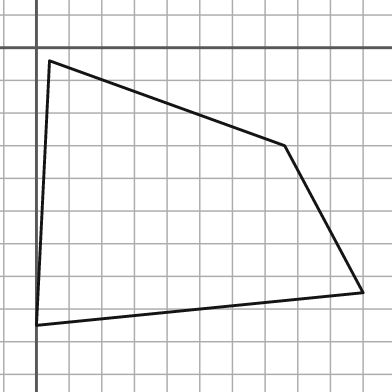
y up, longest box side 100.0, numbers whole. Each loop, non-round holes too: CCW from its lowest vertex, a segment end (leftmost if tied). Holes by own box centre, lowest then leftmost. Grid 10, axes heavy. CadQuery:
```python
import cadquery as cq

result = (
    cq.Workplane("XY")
    .moveTo(0.0, -85.0)
    .lineTo(100.0, -75.0)
    .lineTo(76.0, -30.0)
    .lineTo(4.0, -4.0)
    .close()
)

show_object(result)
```